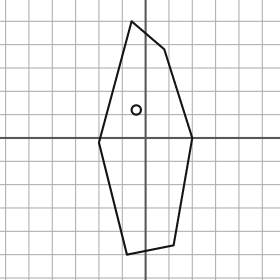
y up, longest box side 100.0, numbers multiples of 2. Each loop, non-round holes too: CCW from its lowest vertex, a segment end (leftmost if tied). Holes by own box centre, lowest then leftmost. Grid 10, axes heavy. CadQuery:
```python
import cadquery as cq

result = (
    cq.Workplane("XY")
    .moveTo(-8.0, -50.0)
    .lineTo(12.0, -46.0)
    .lineTo(20.0, 0.0)
    .lineTo(8.0, 38.0)
    .lineTo(-6.0, 50.0)
    .lineTo(-20.0, -2.0)
    .close()
    .moveTo(-4.0, 12.0)
    .circle(2.0)
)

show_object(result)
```